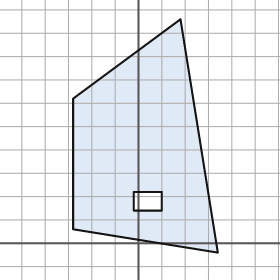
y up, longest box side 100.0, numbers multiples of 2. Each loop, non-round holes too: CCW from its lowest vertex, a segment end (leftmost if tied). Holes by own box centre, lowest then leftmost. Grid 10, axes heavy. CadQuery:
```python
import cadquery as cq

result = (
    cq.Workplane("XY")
    .moveTo(34.0, -4.0)
    .lineTo(18.0, 96.0)
    .lineTo(-28.0, 62.0)
    .lineTo(-28.0, 6.0)
    .close()
    .moveTo(-2.0, 14.0)
    .lineTo(10.0, 14.0)
    .lineTo(10.0, 22.0)
    .lineTo(-2.0, 22.0)
    .close()
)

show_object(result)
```